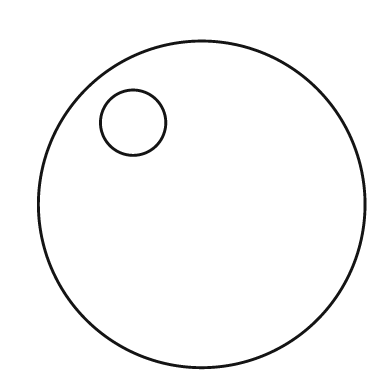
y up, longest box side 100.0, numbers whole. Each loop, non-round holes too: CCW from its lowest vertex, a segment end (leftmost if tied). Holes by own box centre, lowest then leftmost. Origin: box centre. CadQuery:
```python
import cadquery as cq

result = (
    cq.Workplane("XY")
    .moveTo(0.0, 0.0)
    .circle(50.0)
    .moveTo(-21.0, 25.0)
    .circle(10.0)
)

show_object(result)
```